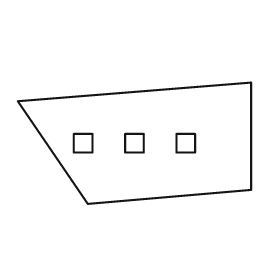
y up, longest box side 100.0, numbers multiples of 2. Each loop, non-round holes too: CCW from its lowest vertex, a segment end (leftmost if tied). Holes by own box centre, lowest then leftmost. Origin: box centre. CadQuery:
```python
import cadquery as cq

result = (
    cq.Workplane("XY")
    .moveTo(-20.0, -26.0)
    .lineTo(50.0, -20.0)
    .lineTo(50.0, 26.0)
    .lineTo(-50.0, 18.0)
    .close()
    .moveTo(-26.0, -4.0)
    .lineTo(-18.0, -4.0)
    .lineTo(-18.0, 4.0)
    .lineTo(-26.0, 4.0)
    .close()
    .moveTo(-4.0, -4.0)
    .lineTo(4.0, -4.0)
    .lineTo(4.0, 4.0)
    .lineTo(-4.0, 4.0)
    .close()
    .moveTo(18.0, -4.0)
    .lineTo(26.0, -4.0)
    .lineTo(26.0, 4.0)
    .lineTo(18.0, 4.0)
    .close()
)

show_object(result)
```